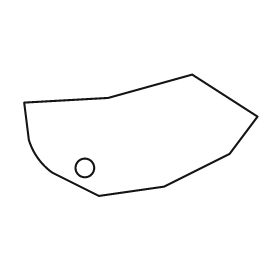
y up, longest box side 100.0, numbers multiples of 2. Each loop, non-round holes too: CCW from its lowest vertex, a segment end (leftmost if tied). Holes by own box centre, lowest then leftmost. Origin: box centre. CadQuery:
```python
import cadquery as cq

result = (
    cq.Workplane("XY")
    .moveTo(-18.0, -26.0)
    .lineTo(10.0, -22.0)
    .lineTo(38.0, -8.0)
    .lineTo(50.0, 8.0)
    .lineTo(22.0, 26.0)
    .lineTo(-14.0, 16.0)
    .lineTo(-50.0, 14.0)
    .lineTo(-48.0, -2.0)
    .threePointArc((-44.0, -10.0), (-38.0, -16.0))
    .close()
    .moveTo(-24.0, -14.0)
    .circle(4.0)
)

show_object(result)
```